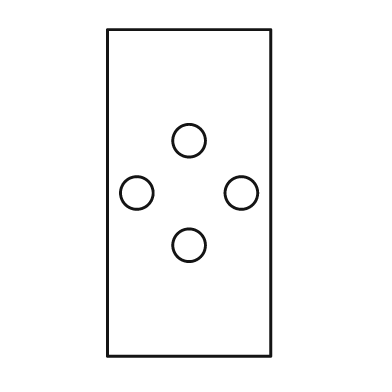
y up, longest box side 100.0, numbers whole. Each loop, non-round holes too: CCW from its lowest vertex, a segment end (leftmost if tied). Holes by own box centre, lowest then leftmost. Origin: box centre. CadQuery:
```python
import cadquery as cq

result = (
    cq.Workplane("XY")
    .moveTo(-25.0, -50.0)
    .lineTo(25.0, -50.0)
    .lineTo(25.0, 50.0)
    .lineTo(-25.0, 50.0)
    .close()
    .moveTo(0.0, -16.0)
    .circle(5.0)
    .moveTo(-16.0, 0.0)
    .circle(5.0)
    .moveTo(16.0, 0.0)
    .circle(5.0)
    .moveTo(0.0, 16.0)
    .circle(5.0)
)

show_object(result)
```